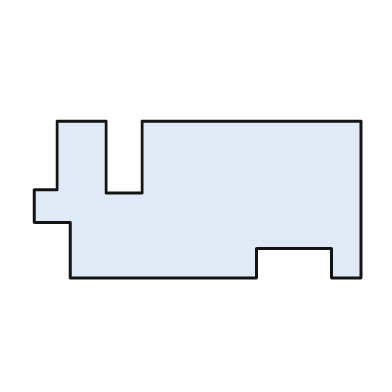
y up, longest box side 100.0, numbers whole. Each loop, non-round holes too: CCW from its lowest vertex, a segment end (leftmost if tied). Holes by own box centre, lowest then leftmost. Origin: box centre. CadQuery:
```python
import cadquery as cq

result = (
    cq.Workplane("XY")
    .moveTo(-39.0, -24.0)
    .lineTo(18.0, -24.0)
    .lineTo(18.0, -15.0)
    .lineTo(41.0, -15.0)
    .lineTo(41.0, -24.0)
    .lineTo(50.0, -24.0)
    .lineTo(50.0, 24.0)
    .lineTo(-17.0, 24.0)
    .lineTo(-17.0, 2.0)
    .lineTo(-28.0, 2.0)
    .lineTo(-28.0, 24.0)
    .lineTo(-43.0, 24.0)
    .lineTo(-43.0, 3.0)
    .lineTo(-50.0, 3.0)
    .lineTo(-50.0, -7.0)
    .lineTo(-39.0, -7.0)
    .close()
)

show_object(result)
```